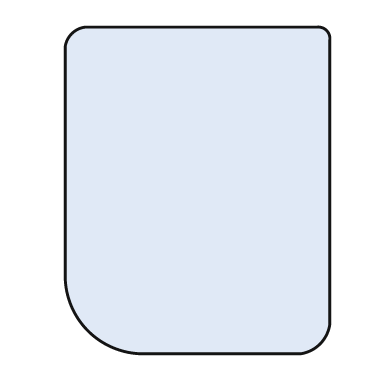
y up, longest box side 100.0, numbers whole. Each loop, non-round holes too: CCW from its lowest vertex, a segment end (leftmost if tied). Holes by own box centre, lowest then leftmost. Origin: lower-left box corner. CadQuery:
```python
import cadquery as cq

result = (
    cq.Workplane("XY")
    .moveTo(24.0, 0.0)
    .lineTo(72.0, 0.0)
    .threePointArc((78.0, 3.0), (81.0, 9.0))
    .lineTo(81.0, 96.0)
    .threePointArc((80.0, 99.0), (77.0, 100.0))
    .lineTo(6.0, 100.0)
    .threePointArc((2.0, 98.0), (0.0, 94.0))
    .lineTo(0.0, 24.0)
    .threePointArc((7.0, 7.0), (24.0, 0.0))
    .close()
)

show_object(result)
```